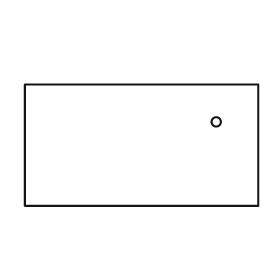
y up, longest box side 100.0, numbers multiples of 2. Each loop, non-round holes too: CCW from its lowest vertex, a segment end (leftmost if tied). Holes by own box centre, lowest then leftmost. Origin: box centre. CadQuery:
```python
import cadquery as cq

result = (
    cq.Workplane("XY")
    .moveTo(-50.0, -26.0)
    .lineTo(50.0, -26.0)
    .lineTo(50.0, 26.0)
    .lineTo(-50.0, 26.0)
    .close()
    .moveTo(32.0, 10.0)
    .circle(2.0)
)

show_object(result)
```